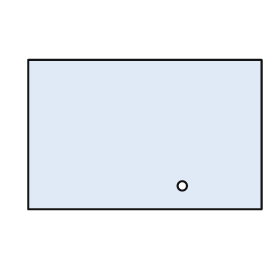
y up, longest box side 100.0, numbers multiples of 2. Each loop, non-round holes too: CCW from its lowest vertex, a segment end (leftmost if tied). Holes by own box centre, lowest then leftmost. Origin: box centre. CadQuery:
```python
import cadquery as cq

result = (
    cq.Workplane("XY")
    .moveTo(-50.0, -32.0)
    .lineTo(50.0, -32.0)
    .lineTo(50.0, 32.0)
    .lineTo(-50.0, 32.0)
    .close()
    .moveTo(16.0, -22.0)
    .circle(2.0)
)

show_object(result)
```